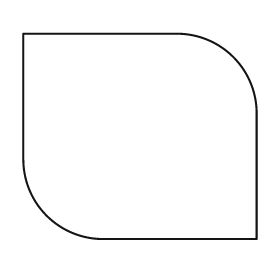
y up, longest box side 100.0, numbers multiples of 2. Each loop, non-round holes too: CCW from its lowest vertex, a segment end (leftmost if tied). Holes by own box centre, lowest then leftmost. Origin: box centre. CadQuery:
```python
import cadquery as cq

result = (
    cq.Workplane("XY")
    .moveTo(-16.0, -44.0)
    .lineTo(50.0, -44.0)
    .lineTo(50.0, 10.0)
    .threePointArc((40.0, 34.0), (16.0, 44.0))
    .lineTo(-50.0, 44.0)
    .lineTo(-50.0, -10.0)
    .threePointArc((-40.0, -34.0), (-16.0, -44.0))
    .close()
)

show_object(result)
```